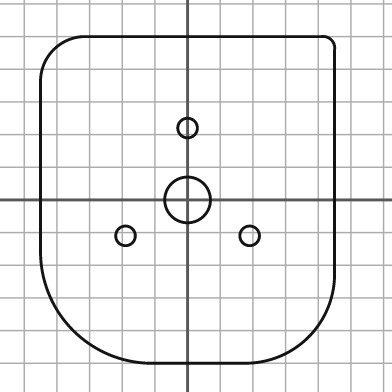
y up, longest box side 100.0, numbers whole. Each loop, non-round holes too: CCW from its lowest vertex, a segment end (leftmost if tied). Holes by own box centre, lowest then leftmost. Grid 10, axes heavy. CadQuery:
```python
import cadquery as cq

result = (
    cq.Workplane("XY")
    .moveTo(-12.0, -50.0)
    .lineTo(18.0, -50.0)
    .threePointArc((37.0, -42.0), (45.0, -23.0))
    .lineTo(45.0, 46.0)
    .threePointArc((44.0, 49.0), (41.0, 50.0))
    .lineTo(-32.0, 50.0)
    .threePointArc((-41.0, 46.0), (-45.0, 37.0))
    .lineTo(-45.0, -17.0)
    .threePointArc((-35.0, -40.0), (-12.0, -50.0))
    .close()
    .moveTo(-19.0, -11.0)
    .circle(3.0)
    .moveTo(19.0, -11.0)
    .circle(3.0)
    .moveTo(0.0, 0.0)
    .circle(7.0)
    .moveTo(0.0, 22.0)
    .circle(3.0)
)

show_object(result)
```